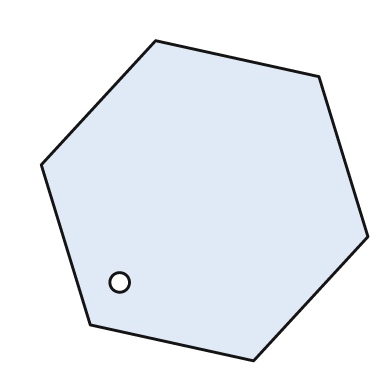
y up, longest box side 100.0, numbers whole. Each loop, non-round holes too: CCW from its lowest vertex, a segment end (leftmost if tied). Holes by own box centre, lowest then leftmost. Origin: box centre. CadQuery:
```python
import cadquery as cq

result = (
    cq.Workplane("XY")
    .moveTo(15.0, -49.0)
    .lineTo(50.0, -11.0)
    .lineTo(35.0, 38.0)
    .lineTo(-15.0, 49.0)
    .lineTo(-50.0, 11.0)
    .lineTo(-35.0, -38.0)
    .close()
    .moveTo(-26.0, -25.0)
    .circle(3.0)
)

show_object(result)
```